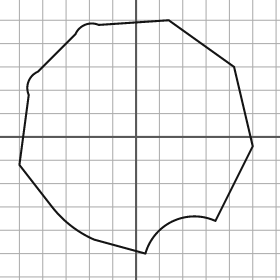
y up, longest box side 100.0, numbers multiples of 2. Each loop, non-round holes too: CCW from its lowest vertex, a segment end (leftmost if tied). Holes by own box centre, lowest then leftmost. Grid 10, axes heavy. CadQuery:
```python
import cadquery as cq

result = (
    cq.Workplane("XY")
    .moveTo(4.0, -50.0)
    .threePointArc((16.0, -36.0), (34.0, -36.0))
    .lineTo(50.0, -4.0)
    .lineTo(42.0, 30.0)
    .lineTo(14.0, 50.0)
    .lineTo(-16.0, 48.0)
    .threePointArc((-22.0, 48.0), (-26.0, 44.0))
    .lineTo(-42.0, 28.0)
    .threePointArc((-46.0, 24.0), (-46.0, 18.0))
    .lineTo(-50.0, -12.0)
    .lineTo(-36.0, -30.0)
    .threePointArc((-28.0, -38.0), (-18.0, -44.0))
    .close()
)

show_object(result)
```